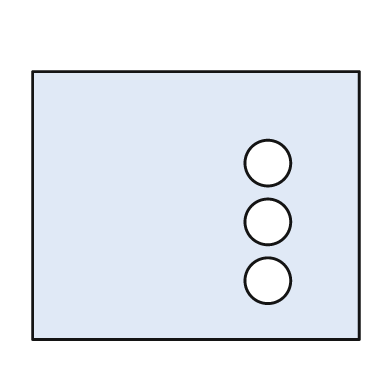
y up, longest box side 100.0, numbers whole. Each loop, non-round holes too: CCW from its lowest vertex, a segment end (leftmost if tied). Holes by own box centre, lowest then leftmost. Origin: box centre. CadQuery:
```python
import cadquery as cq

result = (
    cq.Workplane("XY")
    .moveTo(-50.0, -41.0)
    .lineTo(50.0, -41.0)
    .lineTo(50.0, 41.0)
    .lineTo(-50.0, 41.0)
    .close()
    .moveTo(22.0, -23.0)
    .circle(7.0)
    .moveTo(22.0, -5.0)
    .circle(7.0)
    .moveTo(22.0, 13.0)
    .circle(7.0)
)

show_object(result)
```